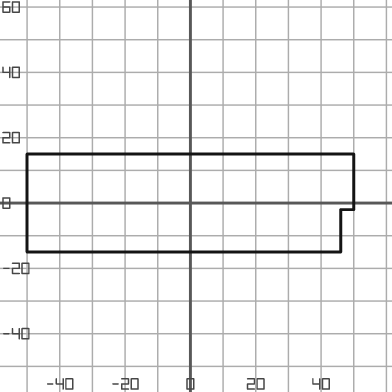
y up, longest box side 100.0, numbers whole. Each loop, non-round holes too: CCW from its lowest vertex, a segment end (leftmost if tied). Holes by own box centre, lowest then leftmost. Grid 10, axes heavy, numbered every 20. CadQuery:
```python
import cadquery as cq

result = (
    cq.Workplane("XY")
    .moveTo(-50.0, -15.0)
    .lineTo(46.0, -15.0)
    .lineTo(46.0, -2.0)
    .lineTo(50.0, -2.0)
    .lineTo(50.0, 15.0)
    .lineTo(-50.0, 15.0)
    .close()
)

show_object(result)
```